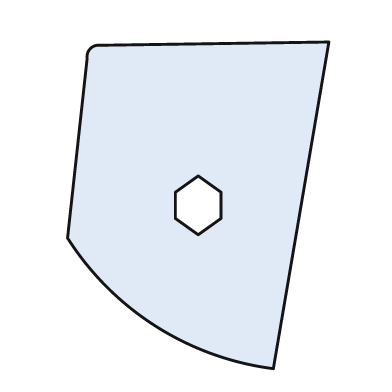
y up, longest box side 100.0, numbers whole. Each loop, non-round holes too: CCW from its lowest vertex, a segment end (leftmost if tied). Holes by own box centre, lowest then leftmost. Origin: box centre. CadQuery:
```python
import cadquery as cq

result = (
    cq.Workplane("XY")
    .moveTo(23.0, -50.0)
    .lineTo(40.0, 50.0)
    .lineTo(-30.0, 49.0)
    .threePointArc((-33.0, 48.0), (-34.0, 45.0))
    .lineTo(-40.0, -10.0)
    .threePointArc((-13.0, -37.0), (23.0, -50.0))
    .close()
    .moveTo(0.0, -9.0)
    .lineTo(7.0, -4.0)
    .lineTo(7.0, 4.0)
    .lineTo(0.0, 9.0)
    .lineTo(-7.0, 4.0)
    .lineTo(-7.0, -4.0)
    .close()
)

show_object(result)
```